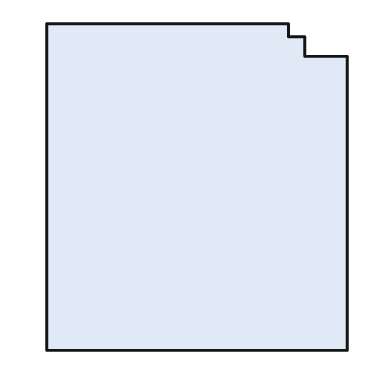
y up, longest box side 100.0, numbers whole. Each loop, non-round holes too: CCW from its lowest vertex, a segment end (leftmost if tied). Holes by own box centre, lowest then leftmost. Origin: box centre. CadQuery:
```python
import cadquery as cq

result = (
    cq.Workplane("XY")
    .moveTo(-46.0, -50.0)
    .lineTo(46.0, -50.0)
    .lineTo(46.0, 40.0)
    .lineTo(33.0, 40.0)
    .lineTo(33.0, 46.0)
    .lineTo(28.0, 46.0)
    .lineTo(28.0, 50.0)
    .lineTo(-46.0, 50.0)
    .close()
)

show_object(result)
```